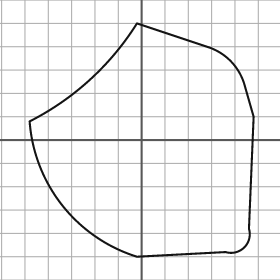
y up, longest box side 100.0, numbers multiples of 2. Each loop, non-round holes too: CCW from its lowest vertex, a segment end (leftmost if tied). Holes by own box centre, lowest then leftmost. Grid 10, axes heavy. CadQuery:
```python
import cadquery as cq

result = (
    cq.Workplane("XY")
    .moveTo(-2.0, -50.0)
    .lineTo(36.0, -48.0)
    .threePointArc((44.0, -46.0), (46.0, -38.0))
    .lineTo(48.0, 10.0)
    .lineTo(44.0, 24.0)
    .threePointArc((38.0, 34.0), (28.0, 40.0))
    .lineTo(-2.0, 50.0)
    .threePointArc((-22.0, 26.0), (-48.0, 8.0))
    .threePointArc((-34.0, -28.0), (-2.0, -50.0))
    .close()
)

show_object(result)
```